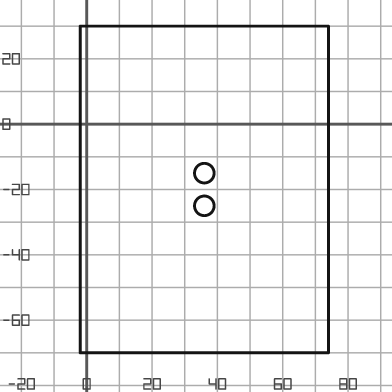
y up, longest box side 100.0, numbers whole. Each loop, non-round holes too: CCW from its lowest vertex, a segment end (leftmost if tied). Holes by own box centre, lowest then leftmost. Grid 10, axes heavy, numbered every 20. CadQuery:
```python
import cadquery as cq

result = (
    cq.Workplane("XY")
    .moveTo(-2.0, -70.0)
    .lineTo(74.0, -70.0)
    .lineTo(74.0, 30.0)
    .lineTo(-2.0, 30.0)
    .close()
    .moveTo(36.0, -25.0)
    .circle(3.0)
    .moveTo(36.0, -15.0)
    .circle(3.0)
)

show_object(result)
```